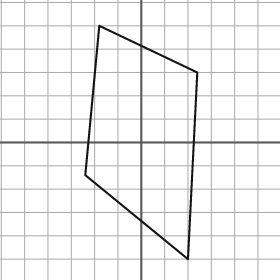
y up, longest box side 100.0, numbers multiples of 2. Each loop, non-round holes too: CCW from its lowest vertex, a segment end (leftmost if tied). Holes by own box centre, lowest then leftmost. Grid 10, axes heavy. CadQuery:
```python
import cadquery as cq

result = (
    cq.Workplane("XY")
    .moveTo(20.0, -50.0)
    .lineTo(24.0, 30.0)
    .lineTo(-18.0, 50.0)
    .lineTo(-24.0, -14.0)
    .close()
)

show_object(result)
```